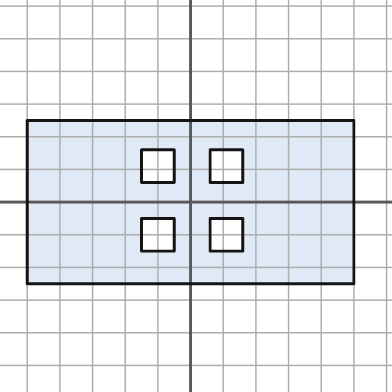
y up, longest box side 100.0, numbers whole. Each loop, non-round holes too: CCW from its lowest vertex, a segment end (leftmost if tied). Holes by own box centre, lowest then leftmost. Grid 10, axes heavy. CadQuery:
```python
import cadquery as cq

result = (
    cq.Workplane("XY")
    .moveTo(-50.0, -25.0)
    .lineTo(50.0, -25.0)
    .lineTo(50.0, 25.0)
    .lineTo(-50.0, 25.0)
    .close()
    .moveTo(-15.0, -15.0)
    .lineTo(-5.0, -15.0)
    .lineTo(-5.0, -5.0)
    .lineTo(-15.0, -5.0)
    .close()
    .moveTo(6.0, -15.0)
    .lineTo(16.0, -15.0)
    .lineTo(16.0, -5.0)
    .lineTo(6.0, -5.0)
    .close()
    .moveTo(-15.0, 6.0)
    .lineTo(-5.0, 6.0)
    .lineTo(-5.0, 16.0)
    .lineTo(-15.0, 16.0)
    .close()
    .moveTo(6.0, 6.0)
    .lineTo(16.0, 6.0)
    .lineTo(16.0, 16.0)
    .lineTo(6.0, 16.0)
    .close()
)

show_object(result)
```